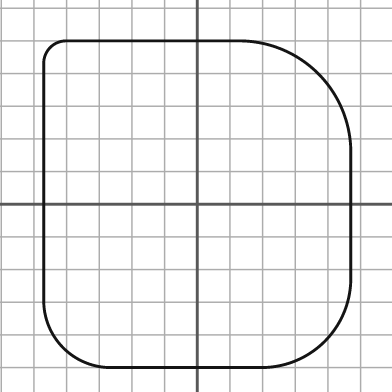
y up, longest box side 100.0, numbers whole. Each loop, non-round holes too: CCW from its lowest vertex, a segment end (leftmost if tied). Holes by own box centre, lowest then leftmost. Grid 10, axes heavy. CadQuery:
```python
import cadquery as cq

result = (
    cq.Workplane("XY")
    .moveTo(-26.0, -50.0)
    .lineTo(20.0, -50.0)
    .threePointArc((39.0, -42.0), (47.0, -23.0))
    .lineTo(47.0, 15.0)
    .threePointArc((37.0, 40.0), (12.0, 50.0))
    .lineTo(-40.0, 50.0)
    .threePointArc((-45.0, 48.0), (-47.0, 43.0))
    .lineTo(-47.0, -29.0)
    .threePointArc((-41.0, -44.0), (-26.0, -50.0))
    .close()
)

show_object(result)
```